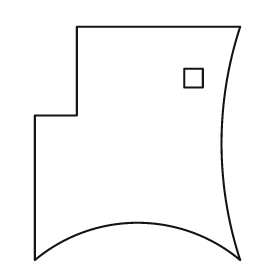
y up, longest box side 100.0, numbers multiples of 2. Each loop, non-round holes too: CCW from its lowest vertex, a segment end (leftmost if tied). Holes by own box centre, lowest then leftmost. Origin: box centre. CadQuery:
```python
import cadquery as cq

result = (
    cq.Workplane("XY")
    .moveTo(-44.0, -50.0)
    .threePointArc((0.0, -34.0), (44.0, -50.0))
    .threePointArc((36.0, 0.0), (44.0, 50.0))
    .lineTo(-26.0, 50.0)
    .lineTo(-26.0, 12.0)
    .lineTo(-44.0, 12.0)
    .close()
    .moveTo(20.0, 24.0)
    .lineTo(28.0, 24.0)
    .lineTo(28.0, 32.0)
    .lineTo(20.0, 32.0)
    .close()
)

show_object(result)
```